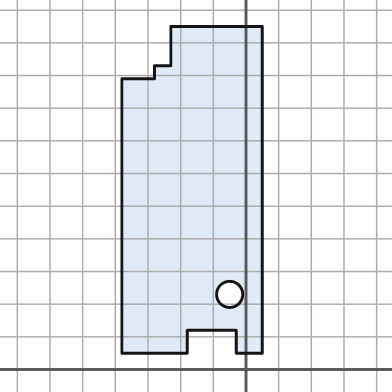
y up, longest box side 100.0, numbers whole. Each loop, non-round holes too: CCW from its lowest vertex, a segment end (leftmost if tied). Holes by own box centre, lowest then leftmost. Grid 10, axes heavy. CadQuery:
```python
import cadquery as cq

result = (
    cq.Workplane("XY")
    .moveTo(-38.0, 5.0)
    .lineTo(-18.0, 5.0)
    .lineTo(-18.0, 12.0)
    .lineTo(-3.0, 12.0)
    .lineTo(-3.0, 5.0)
    .lineTo(5.0, 5.0)
    .lineTo(5.0, 105.0)
    .lineTo(-23.0, 105.0)
    .lineTo(-23.0, 93.0)
    .lineTo(-28.0, 93.0)
    .lineTo(-28.0, 89.0)
    .lineTo(-38.0, 89.0)
    .close()
    .moveTo(-5.0, 23.0)
    .circle(4.0)
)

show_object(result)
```